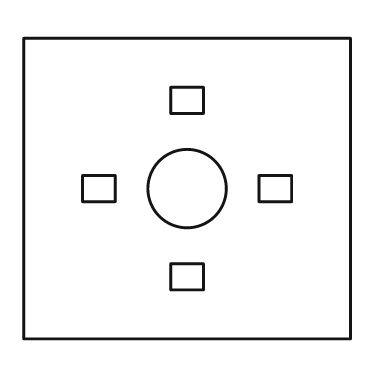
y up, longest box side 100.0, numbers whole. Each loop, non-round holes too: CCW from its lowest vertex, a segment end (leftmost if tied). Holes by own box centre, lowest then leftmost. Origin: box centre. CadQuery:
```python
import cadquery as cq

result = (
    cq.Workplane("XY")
    .moveTo(-50.0, -46.0)
    .lineTo(50.0, -46.0)
    .lineTo(50.0, 46.0)
    .lineTo(-50.0, 46.0)
    .close()
    .moveTo(-5.0, -31.0)
    .lineTo(5.0, -31.0)
    .lineTo(5.0, -23.0)
    .lineTo(-5.0, -23.0)
    .close()
    .moveTo(-32.0, -4.0)
    .lineTo(-22.0, -4.0)
    .lineTo(-22.0, 4.0)
    .lineTo(-32.0, 4.0)
    .close()
    .moveTo(0.0, 0.0)
    .circle(12.0)
    .moveTo(22.0, -4.0)
    .lineTo(32.0, -4.0)
    .lineTo(32.0, 4.0)
    .lineTo(22.0, 4.0)
    .close()
    .moveTo(-5.0, 23.0)
    .lineTo(5.0, 23.0)
    .lineTo(5.0, 31.0)
    .lineTo(-5.0, 31.0)
    .close()
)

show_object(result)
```